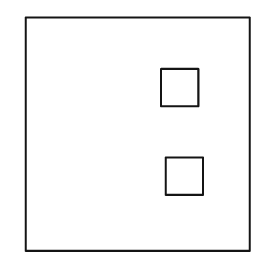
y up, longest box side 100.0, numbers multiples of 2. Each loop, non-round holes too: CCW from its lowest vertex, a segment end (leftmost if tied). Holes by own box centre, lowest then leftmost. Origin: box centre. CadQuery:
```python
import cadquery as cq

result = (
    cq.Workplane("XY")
    .moveTo(-48.0, -50.0)
    .lineTo(48.0, -50.0)
    .lineTo(48.0, 50.0)
    .lineTo(-48.0, 50.0)
    .close()
    .moveTo(12.0, -26.0)
    .lineTo(28.0, -26.0)
    .lineTo(28.0, -10.0)
    .lineTo(12.0, -10.0)
    .close()
    .moveTo(10.0, 12.0)
    .lineTo(26.0, 12.0)
    .lineTo(26.0, 28.0)
    .lineTo(10.0, 28.0)
    .close()
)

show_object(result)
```